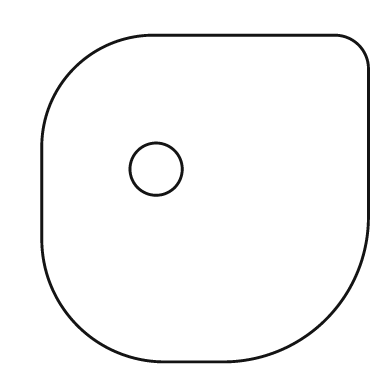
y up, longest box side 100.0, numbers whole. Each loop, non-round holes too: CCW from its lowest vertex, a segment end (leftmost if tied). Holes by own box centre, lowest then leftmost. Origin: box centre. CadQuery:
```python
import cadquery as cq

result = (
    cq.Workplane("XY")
    .moveTo(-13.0, -50.0)
    .lineTo(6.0, -50.0)
    .threePointArc((37.0, -37.0), (50.0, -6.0))
    .lineTo(50.0, 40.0)
    .threePointArc((47.0, 47.0), (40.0, 50.0))
    .lineTo(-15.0, 50.0)
    .threePointArc((-40.0, 40.0), (-50.0, 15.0))
    .lineTo(-50.0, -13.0)
    .threePointArc((-39.0, -39.0), (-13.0, -50.0))
    .close()
    .moveTo(-15.0, 9.0)
    .circle(8.0)
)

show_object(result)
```